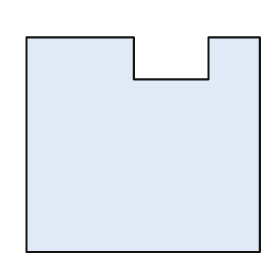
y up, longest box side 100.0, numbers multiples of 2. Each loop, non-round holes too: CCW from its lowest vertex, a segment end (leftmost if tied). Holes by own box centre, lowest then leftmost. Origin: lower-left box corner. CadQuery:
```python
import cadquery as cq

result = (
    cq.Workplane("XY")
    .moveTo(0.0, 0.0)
    .lineTo(100.0, 0.0)
    .lineTo(100.0, 92.0)
    .lineTo(78.0, 92.0)
    .lineTo(78.0, 74.0)
    .lineTo(46.0, 74.0)
    .lineTo(46.0, 92.0)
    .lineTo(0.0, 92.0)
    .close()
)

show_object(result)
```